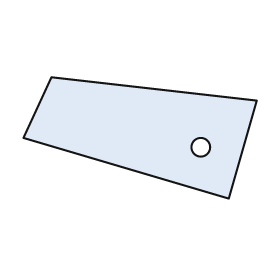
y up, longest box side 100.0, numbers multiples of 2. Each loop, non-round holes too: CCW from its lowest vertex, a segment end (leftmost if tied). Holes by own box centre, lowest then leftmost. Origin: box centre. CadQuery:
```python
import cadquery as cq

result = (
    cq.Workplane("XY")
    .moveTo(38.0, -26.0)
    .lineTo(50.0, 16.0)
    .lineTo(-38.0, 26.0)
    .lineTo(-50.0, 0.0)
    .close()
    .moveTo(26.0, -4.0)
    .circle(4.0)
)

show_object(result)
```